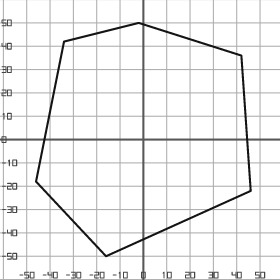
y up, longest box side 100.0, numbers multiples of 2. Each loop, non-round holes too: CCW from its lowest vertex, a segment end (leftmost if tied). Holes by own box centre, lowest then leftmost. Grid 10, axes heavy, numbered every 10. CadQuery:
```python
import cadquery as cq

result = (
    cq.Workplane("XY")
    .moveTo(-16.0, -50.0)
    .lineTo(46.0, -22.0)
    .lineTo(42.0, 36.0)
    .lineTo(-2.0, 50.0)
    .lineTo(-34.0, 42.0)
    .lineTo(-46.0, -18.0)
    .close()
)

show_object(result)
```